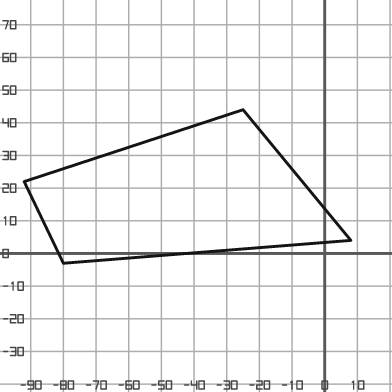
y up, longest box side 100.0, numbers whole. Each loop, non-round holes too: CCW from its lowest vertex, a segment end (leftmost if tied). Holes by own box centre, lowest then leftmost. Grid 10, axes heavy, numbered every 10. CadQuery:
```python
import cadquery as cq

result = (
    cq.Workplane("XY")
    .moveTo(-80.0, -3.0)
    .lineTo(8.0, 4.0)
    .lineTo(-25.0, 44.0)
    .lineTo(-92.0, 22.0)
    .close()
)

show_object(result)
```